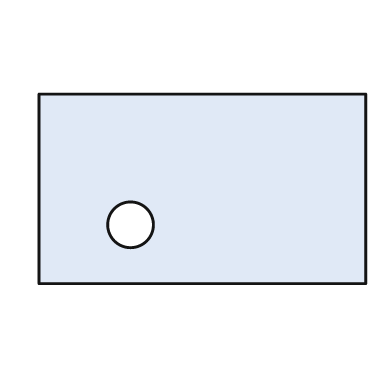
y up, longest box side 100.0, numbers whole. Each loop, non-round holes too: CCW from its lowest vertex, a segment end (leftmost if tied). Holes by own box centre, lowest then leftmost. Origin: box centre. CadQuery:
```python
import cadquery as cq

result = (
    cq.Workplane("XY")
    .moveTo(-50.0, -29.0)
    .lineTo(50.0, -29.0)
    .lineTo(50.0, 29.0)
    .lineTo(-50.0, 29.0)
    .close()
    .moveTo(-22.0, -11.0)
    .circle(7.0)
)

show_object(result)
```